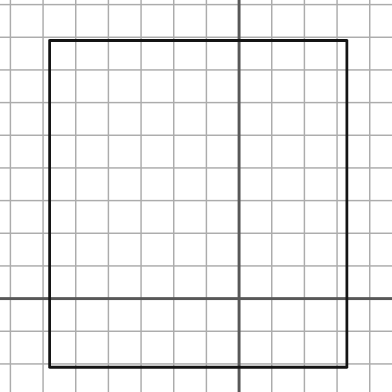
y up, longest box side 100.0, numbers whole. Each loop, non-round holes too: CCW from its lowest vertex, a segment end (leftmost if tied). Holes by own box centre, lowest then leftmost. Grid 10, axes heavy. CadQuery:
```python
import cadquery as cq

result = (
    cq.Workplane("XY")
    .moveTo(-58.0, -21.0)
    .lineTo(33.0, -21.0)
    .lineTo(33.0, 79.0)
    .lineTo(-58.0, 79.0)
    .close()
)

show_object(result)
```